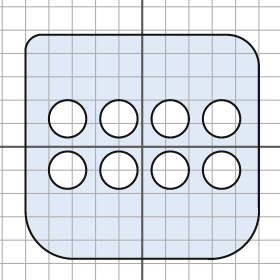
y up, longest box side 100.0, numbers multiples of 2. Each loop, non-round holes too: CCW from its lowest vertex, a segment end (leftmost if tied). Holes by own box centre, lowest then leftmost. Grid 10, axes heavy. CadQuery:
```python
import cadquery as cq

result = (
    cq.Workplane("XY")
    .moveTo(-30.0, -48.0)
    .lineTo(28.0, -48.0)
    .threePointArc((44.0, -42.0), (50.0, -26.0))
    .lineTo(50.0, 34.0)
    .threePointArc((46.0, 44.0), (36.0, 48.0))
    .lineTo(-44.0, 48.0)
    .threePointArc((-48.0, 46.0), (-50.0, 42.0))
    .lineTo(-50.0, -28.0)
    .threePointArc((-44.0, -42.0), (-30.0, -48.0))
    .close()
    .moveTo(-32.0, -10.0)
    .circle(8.0)
    .moveTo(-10.0, -10.0)
    .circle(8.0)
    .moveTo(12.0, -10.0)
    .circle(8.0)
    .moveTo(34.0, -10.0)
    .circle(8.0)
    .moveTo(-32.0, 12.0)
    .circle(8.0)
    .moveTo(-10.0, 12.0)
    .circle(8.0)
    .moveTo(12.0, 12.0)
    .circle(8.0)
    .moveTo(34.0, 12.0)
    .circle(8.0)
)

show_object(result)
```